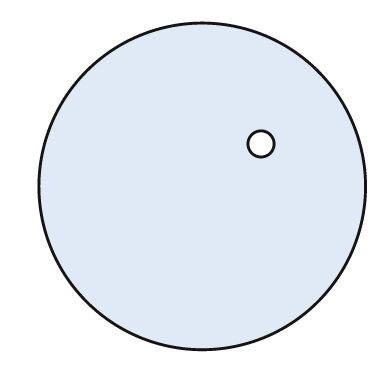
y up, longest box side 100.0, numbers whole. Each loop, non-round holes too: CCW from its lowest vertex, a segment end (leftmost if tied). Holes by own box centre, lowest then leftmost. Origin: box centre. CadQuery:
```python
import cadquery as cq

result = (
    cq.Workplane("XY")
    .moveTo(0.0, 0.0)
    .circle(50.0)
    .moveTo(18.0, 13.0)
    .circle(4.0)
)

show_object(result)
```